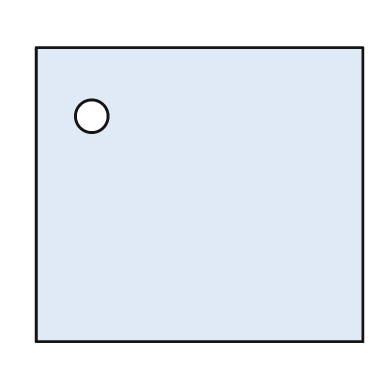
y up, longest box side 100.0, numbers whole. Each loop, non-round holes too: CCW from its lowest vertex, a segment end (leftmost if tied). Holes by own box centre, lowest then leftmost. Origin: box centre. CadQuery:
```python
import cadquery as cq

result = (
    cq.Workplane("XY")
    .moveTo(-50.0, -45.0)
    .lineTo(50.0, -45.0)
    .lineTo(50.0, 45.0)
    .lineTo(-50.0, 45.0)
    .close()
    .moveTo(-33.0, 24.0)
    .circle(5.0)
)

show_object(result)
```